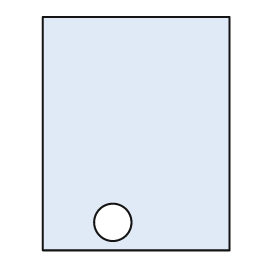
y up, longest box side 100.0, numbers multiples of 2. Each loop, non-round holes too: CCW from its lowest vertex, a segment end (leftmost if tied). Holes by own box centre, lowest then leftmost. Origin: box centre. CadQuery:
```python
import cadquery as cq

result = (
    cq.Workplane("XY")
    .moveTo(-40.0, -50.0)
    .lineTo(40.0, -50.0)
    .lineTo(40.0, 50.0)
    .lineTo(-40.0, 50.0)
    .close()
    .moveTo(-10.0, -38.0)
    .circle(8.0)
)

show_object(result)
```